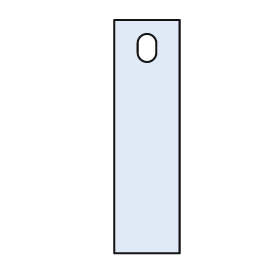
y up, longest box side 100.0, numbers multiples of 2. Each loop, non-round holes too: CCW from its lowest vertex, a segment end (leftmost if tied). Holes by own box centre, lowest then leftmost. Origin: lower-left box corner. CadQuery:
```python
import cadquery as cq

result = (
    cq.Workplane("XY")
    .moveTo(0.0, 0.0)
    .lineTo(28.0, 0.0)
    .lineTo(28.0, 100.0)
    .lineTo(0.0, 100.0)
    .close()
    .moveTo(10.0, 86.0)
    .threePointArc((14.0, 82.0), (18.0, 86.0))
    .lineTo(18.0, 90.0)
    .threePointArc((14.0, 94.0), (10.0, 90.0))
    .close()
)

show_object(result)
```